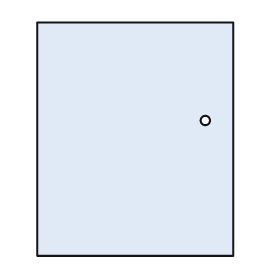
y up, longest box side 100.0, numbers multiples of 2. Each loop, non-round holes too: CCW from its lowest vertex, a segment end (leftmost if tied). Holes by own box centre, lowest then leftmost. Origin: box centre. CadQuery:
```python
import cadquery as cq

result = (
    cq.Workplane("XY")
    .moveTo(-42.0, -50.0)
    .lineTo(42.0, -50.0)
    .lineTo(42.0, 50.0)
    .lineTo(-42.0, 50.0)
    .close()
    .moveTo(30.0, 8.0)
    .circle(2.0)
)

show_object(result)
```